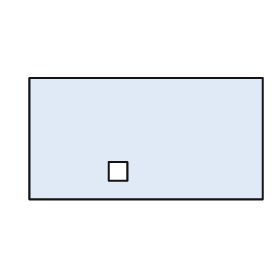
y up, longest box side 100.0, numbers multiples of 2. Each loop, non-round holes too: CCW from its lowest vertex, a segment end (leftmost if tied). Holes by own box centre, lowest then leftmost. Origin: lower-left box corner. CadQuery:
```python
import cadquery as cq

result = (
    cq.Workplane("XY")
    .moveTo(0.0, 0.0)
    .lineTo(100.0, 0.0)
    .lineTo(100.0, 52.0)
    .lineTo(0.0, 52.0)
    .close()
    .moveTo(34.0, 8.0)
    .lineTo(42.0, 8.0)
    .lineTo(42.0, 16.0)
    .lineTo(34.0, 16.0)
    .close()
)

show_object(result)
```